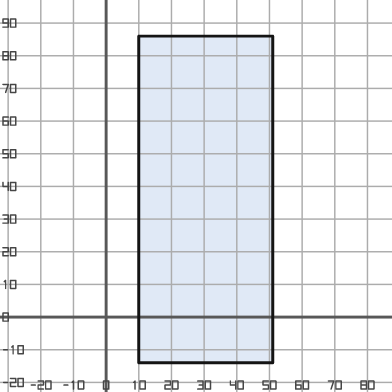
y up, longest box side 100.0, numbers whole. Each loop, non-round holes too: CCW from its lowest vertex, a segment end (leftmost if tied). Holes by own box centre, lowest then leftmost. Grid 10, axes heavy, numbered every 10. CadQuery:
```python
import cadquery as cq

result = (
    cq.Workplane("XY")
    .moveTo(10.0, -14.0)
    .lineTo(51.0, -14.0)
    .lineTo(51.0, 86.0)
    .lineTo(10.0, 86.0)
    .close()
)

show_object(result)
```